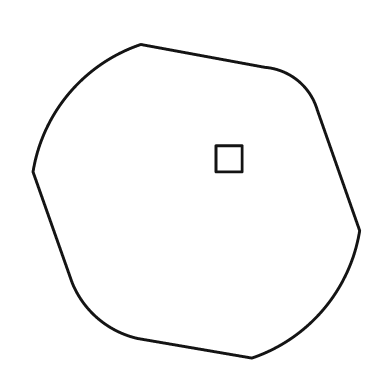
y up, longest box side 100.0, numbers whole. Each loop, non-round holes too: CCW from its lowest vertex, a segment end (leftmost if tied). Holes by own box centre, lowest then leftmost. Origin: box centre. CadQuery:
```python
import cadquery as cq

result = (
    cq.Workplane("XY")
    .moveTo(17.0, -48.0)
    .threePointArc((39.0, -33.0), (50.0, -9.0))
    .lineTo(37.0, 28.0)
    .threePointArc((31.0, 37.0), (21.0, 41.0))
    .lineTo(-17.0, 48.0)
    .threePointArc((-39.0, 33.0), (-50.0, 9.0))
    .lineTo(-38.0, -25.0)
    .threePointArc((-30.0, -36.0), (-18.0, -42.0))
    .close()
    .moveTo(6.0, 9.0)
    .lineTo(14.0, 9.0)
    .lineTo(14.0, 17.0)
    .lineTo(6.0, 17.0)
    .close()
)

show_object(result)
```